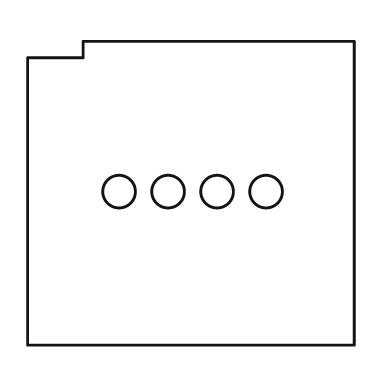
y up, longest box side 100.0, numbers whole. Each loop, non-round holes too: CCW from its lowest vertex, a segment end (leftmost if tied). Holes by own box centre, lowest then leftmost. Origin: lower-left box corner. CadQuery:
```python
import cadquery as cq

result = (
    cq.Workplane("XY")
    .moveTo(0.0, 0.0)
    .lineTo(100.0, 0.0)
    .lineTo(100.0, 93.0)
    .lineTo(17.0, 93.0)
    .lineTo(17.0, 88.0)
    .lineTo(0.0, 88.0)
    .close()
    .moveTo(28.0, 47.0)
    .circle(5.0)
    .moveTo(43.0, 47.0)
    .circle(5.0)
    .moveTo(58.0, 47.0)
    .circle(5.0)
    .moveTo(73.0, 47.0)
    .circle(5.0)
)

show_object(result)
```